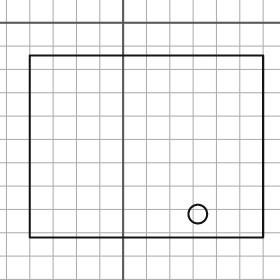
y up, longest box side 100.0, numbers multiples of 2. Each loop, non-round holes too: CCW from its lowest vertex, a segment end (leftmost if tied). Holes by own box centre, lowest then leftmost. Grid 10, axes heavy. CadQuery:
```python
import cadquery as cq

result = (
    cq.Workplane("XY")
    .moveTo(-40.0, -92.0)
    .lineTo(60.0, -92.0)
    .lineTo(60.0, -14.0)
    .lineTo(-40.0, -14.0)
    .close()
    .moveTo(32.0, -82.0)
    .circle(4.0)
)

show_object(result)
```